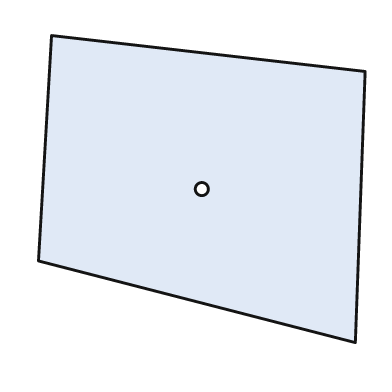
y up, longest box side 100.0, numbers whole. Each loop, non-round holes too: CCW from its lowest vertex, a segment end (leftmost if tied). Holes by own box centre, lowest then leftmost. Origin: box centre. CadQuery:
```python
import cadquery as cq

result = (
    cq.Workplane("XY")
    .moveTo(47.0, -47.0)
    .lineTo(50.0, 36.0)
    .lineTo(-46.0, 47.0)
    .lineTo(-50.0, -22.0)
    .close()
    .moveTo(0.0, 0.0)
    .circle(2.0)
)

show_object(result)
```